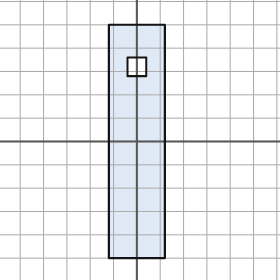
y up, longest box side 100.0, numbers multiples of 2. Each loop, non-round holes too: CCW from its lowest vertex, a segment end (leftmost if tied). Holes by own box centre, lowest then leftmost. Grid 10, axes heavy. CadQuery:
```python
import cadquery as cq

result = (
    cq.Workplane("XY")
    .moveTo(-12.0, -50.0)
    .lineTo(12.0, -50.0)
    .lineTo(12.0, 50.0)
    .lineTo(-12.0, 50.0)
    .close()
    .moveTo(-4.0, 28.0)
    .lineTo(4.0, 28.0)
    .lineTo(4.0, 36.0)
    .lineTo(-4.0, 36.0)
    .close()
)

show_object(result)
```